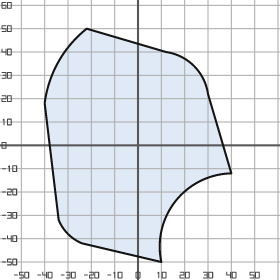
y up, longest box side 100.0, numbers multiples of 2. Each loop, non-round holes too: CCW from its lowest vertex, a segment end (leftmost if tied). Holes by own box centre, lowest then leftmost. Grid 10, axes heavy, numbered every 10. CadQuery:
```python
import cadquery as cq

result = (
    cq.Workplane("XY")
    .moveTo(10.0, -50.0)
    .threePointArc((16.0, -24.0), (40.0, -12.0))
    .lineTo(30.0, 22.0)
    .threePointArc((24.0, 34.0), (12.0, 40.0))
    .lineTo(-22.0, 50.0)
    .threePointArc((-34.0, 36.0), (-40.0, 18.0))
    .lineTo(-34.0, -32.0)
    .threePointArc((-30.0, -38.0), (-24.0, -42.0))
    .close()
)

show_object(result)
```